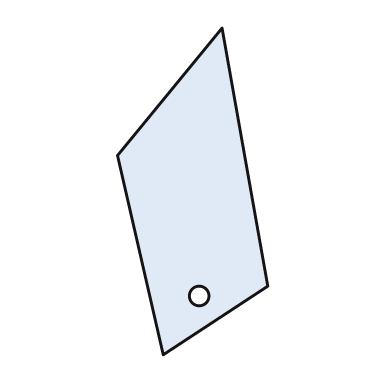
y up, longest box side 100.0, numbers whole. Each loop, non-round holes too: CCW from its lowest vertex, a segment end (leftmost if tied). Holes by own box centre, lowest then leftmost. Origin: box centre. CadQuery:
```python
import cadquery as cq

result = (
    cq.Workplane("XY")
    .moveTo(-9.0, -50.0)
    .lineTo(23.0, -29.0)
    .lineTo(9.0, 50.0)
    .lineTo(-23.0, 11.0)
    .close()
    .moveTo(2.0, -32.0)
    .circle(3.0)
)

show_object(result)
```